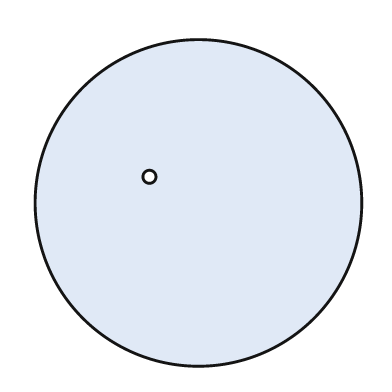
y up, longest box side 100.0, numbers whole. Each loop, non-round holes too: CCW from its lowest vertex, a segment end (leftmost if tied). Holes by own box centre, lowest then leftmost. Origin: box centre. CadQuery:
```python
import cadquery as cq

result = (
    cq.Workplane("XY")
    .moveTo(0.0, 0.0)
    .circle(50.0)
    .moveTo(-15.0, 8.0)
    .circle(2.0)
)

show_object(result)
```